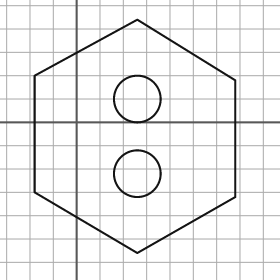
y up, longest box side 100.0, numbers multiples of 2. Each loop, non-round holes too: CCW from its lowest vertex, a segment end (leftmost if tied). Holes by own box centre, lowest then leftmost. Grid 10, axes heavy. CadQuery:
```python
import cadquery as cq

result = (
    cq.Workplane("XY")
    .moveTo(26.0, -56.0)
    .lineTo(68.0, -32.0)
    .lineTo(68.0, 18.0)
    .lineTo(26.0, 44.0)
    .lineTo(-18.0, 20.0)
    .lineTo(-18.0, -30.0)
    .close()
    .moveTo(26.0, -22.0)
    .circle(10.0)
    .moveTo(26.0, 10.0)
    .circle(10.0)
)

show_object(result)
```